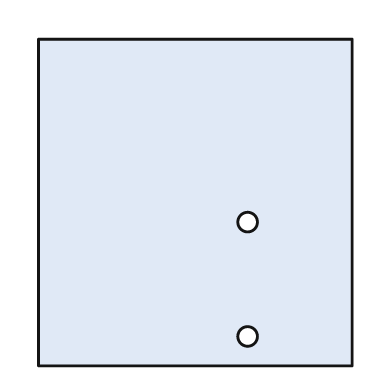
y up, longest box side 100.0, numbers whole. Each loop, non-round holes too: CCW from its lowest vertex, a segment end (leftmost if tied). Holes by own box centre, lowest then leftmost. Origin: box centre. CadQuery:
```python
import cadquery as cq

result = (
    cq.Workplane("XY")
    .moveTo(-48.0, -50.0)
    .lineTo(48.0, -50.0)
    .lineTo(48.0, 50.0)
    .lineTo(-48.0, 50.0)
    .close()
    .moveTo(16.0, -41.0)
    .circle(3.0)
    .moveTo(16.0, -6.0)
    .circle(3.0)
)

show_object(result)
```